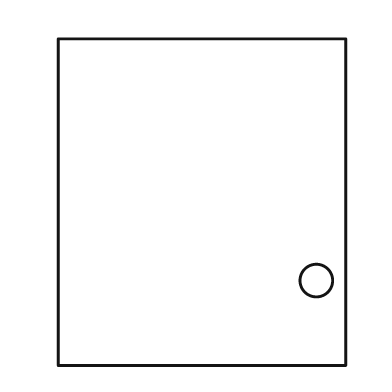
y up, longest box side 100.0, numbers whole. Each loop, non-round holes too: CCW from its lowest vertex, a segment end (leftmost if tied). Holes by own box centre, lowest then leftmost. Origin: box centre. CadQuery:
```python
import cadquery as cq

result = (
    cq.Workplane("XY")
    .moveTo(-44.0, -50.0)
    .lineTo(44.0, -50.0)
    .lineTo(44.0, 50.0)
    .lineTo(-44.0, 50.0)
    .close()
    .moveTo(35.0, -24.0)
    .circle(5.0)
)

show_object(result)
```